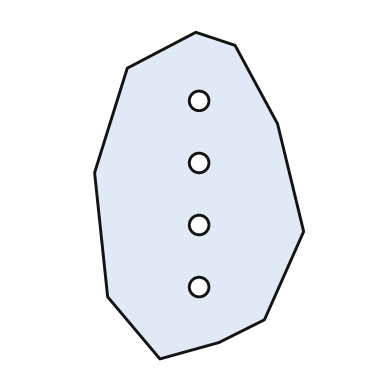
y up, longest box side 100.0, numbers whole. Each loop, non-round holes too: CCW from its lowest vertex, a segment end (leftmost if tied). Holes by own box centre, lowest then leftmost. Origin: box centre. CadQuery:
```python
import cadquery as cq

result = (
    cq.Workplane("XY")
    .moveTo(-12.0, -50.0)
    .lineTo(6.0, -45.0)
    .lineTo(20.0, -38.0)
    .lineTo(32.0, -11.0)
    .lineTo(24.0, 22.0)
    .lineTo(11.0, 46.0)
    .lineTo(-1.0, 50.0)
    .lineTo(-22.0, 39.0)
    .lineTo(-32.0, 7.0)
    .lineTo(-28.0, -31.0)
    .close()
    .moveTo(0.0, -28.0)
    .circle(3.0)
    .moveTo(0.0, -9.0)
    .circle(3.0)
    .moveTo(0.0, 10.0)
    .circle(3.0)
    .moveTo(0.0, 29.0)
    .circle(3.0)
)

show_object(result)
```